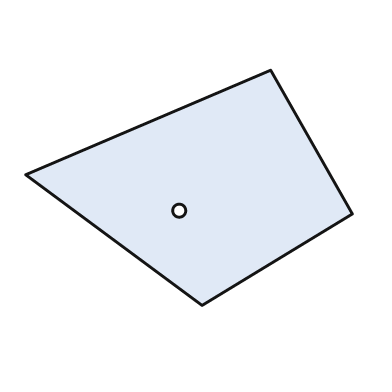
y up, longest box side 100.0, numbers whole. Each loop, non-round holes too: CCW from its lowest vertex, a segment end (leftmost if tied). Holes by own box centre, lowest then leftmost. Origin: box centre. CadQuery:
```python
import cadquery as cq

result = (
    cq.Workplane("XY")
    .moveTo(4.0, -36.0)
    .lineTo(50.0, -8.0)
    .lineTo(25.0, 36.0)
    .lineTo(-50.0, 4.0)
    .close()
    .moveTo(-3.0, -7.0)
    .circle(2.0)
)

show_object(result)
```